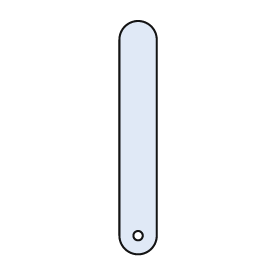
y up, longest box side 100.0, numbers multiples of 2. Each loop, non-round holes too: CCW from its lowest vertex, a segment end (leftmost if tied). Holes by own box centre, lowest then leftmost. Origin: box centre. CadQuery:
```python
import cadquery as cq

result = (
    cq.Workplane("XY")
    .moveTo(-8.0, -42.0)
    .threePointArc((0.0, -50.0), (8.0, -42.0))
    .lineTo(8.0, 42.0)
    .threePointArc((0.0, 50.0), (-8.0, 42.0))
    .close()
    .moveTo(0.0, -42.0)
    .circle(2.0)
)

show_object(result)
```